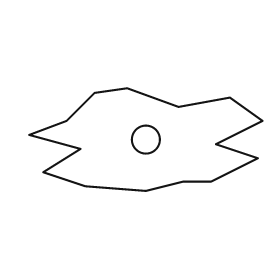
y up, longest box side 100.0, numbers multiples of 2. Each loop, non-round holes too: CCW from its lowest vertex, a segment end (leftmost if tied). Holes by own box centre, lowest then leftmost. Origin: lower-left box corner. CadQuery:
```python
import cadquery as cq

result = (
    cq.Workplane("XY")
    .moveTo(50.0, 0.0)
    .lineTo(66.0, 4.0)
    .lineTo(78.0, 4.0)
    .lineTo(98.0, 14.0)
    .lineTo(80.0, 20.0)
    .lineTo(100.0, 30.0)
    .lineTo(86.0, 40.0)
    .lineTo(64.0, 36.0)
    .lineTo(42.0, 44.0)
    .lineTo(28.0, 42.0)
    .lineTo(16.0, 30.0)
    .lineTo(0.0, 24.0)
    .lineTo(22.0, 18.0)
    .lineTo(6.0, 8.0)
    .lineTo(24.0, 2.0)
    .close()
    .moveTo(50.0, 22.0)
    .circle(6.0)
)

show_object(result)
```